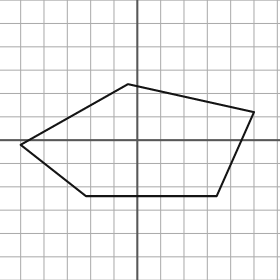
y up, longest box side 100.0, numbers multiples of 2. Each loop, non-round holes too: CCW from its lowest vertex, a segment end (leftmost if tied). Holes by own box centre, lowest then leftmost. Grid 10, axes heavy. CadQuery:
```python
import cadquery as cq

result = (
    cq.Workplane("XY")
    .moveTo(-22.0, -24.0)
    .lineTo(34.0, -24.0)
    .lineTo(50.0, 12.0)
    .lineTo(-4.0, 24.0)
    .lineTo(-50.0, -2.0)
    .close()
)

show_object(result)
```